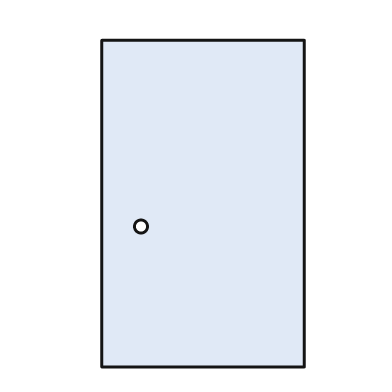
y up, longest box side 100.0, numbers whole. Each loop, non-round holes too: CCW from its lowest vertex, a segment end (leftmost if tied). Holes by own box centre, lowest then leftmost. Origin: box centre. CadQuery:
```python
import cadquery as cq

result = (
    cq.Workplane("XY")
    .moveTo(-31.0, -50.0)
    .lineTo(31.0, -50.0)
    .lineTo(31.0, 50.0)
    .lineTo(-31.0, 50.0)
    .close()
    .moveTo(-19.0, -7.0)
    .circle(2.0)
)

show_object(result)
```